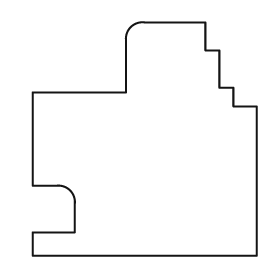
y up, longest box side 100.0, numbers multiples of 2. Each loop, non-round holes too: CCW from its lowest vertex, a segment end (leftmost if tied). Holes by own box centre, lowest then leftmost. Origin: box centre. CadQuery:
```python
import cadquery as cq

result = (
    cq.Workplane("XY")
    .moveTo(-48.0, -50.0)
    .lineTo(48.0, -50.0)
    .lineTo(48.0, 14.0)
    .lineTo(38.0, 14.0)
    .lineTo(38.0, 22.0)
    .lineTo(32.0, 22.0)
    .lineTo(32.0, 38.0)
    .lineTo(26.0, 38.0)
    .lineTo(26.0, 50.0)
    .lineTo(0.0, 50.0)
    .threePointArc((-6.0, 48.0), (-8.0, 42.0))
    .lineTo(-8.0, 20.0)
    .lineTo(-48.0, 20.0)
    .lineTo(-48.0, -20.0)
    .lineTo(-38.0, -20.0)
    .threePointArc((-32.0, -22.0), (-30.0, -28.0))
    .lineTo(-30.0, -40.0)
    .lineTo(-48.0, -40.0)
    .close()
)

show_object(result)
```